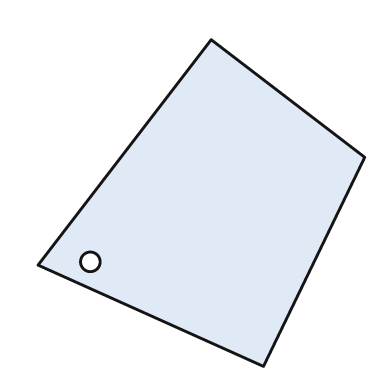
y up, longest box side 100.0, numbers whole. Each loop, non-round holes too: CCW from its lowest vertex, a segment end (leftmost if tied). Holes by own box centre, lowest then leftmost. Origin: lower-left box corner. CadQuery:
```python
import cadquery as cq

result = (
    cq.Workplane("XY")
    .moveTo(69.0, 0.0)
    .lineTo(100.0, 64.0)
    .lineTo(53.0, 100.0)
    .lineTo(0.0, 31.0)
    .close()
    .moveTo(16.0, 32.0)
    .circle(3.0)
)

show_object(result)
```